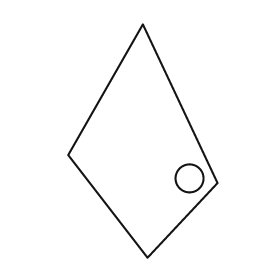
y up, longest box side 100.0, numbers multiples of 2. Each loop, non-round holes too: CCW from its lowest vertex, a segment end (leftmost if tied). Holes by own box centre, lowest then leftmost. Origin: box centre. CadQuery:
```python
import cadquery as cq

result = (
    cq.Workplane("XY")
    .moveTo(2.0, -50.0)
    .lineTo(32.0, -18.0)
    .lineTo(0.0, 50.0)
    .lineTo(-32.0, -6.0)
    .close()
    .moveTo(20.0, -16.0)
    .circle(6.0)
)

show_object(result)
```